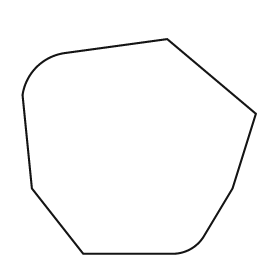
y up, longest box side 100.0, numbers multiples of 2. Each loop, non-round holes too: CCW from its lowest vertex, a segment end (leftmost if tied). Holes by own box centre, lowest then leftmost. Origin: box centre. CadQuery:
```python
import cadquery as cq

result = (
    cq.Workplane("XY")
    .moveTo(-24.0, -46.0)
    .lineTo(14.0, -46.0)
    .threePointArc((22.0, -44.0), (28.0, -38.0))
    .lineTo(40.0, -18.0)
    .lineTo(50.0, 14.0)
    .lineTo(12.0, 46.0)
    .lineTo(-32.0, 40.0)
    .threePointArc((-44.0, 34.0), (-50.0, 22.0))
    .lineTo(-46.0, -18.0)
    .close()
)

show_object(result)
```